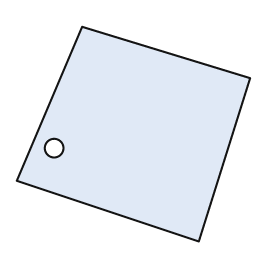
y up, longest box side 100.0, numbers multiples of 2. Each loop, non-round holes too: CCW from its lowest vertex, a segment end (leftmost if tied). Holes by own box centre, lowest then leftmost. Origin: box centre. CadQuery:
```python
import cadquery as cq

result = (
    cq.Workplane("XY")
    .moveTo(28.0, -46.0)
    .lineTo(50.0, 24.0)
    .lineTo(-22.0, 46.0)
    .lineTo(-50.0, -20.0)
    .close()
    .moveTo(-34.0, -6.0)
    .circle(4.0)
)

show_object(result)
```